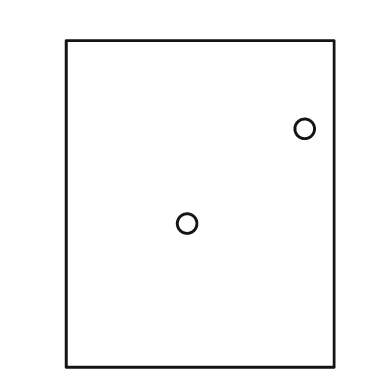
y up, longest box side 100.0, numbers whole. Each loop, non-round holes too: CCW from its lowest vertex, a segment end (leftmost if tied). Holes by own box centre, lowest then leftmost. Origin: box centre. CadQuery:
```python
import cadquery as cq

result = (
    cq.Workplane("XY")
    .moveTo(-41.0, -50.0)
    .lineTo(41.0, -50.0)
    .lineTo(41.0, 50.0)
    .lineTo(-41.0, 50.0)
    .close()
    .moveTo(-4.0, -6.0)
    .circle(3.0)
    .moveTo(32.0, 23.0)
    .circle(3.0)
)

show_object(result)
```